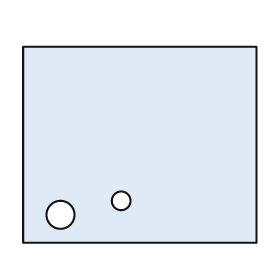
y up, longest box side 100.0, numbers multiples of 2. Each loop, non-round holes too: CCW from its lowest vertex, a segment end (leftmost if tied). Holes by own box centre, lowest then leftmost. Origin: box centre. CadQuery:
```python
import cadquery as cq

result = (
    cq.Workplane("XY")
    .moveTo(-50.0, -42.0)
    .lineTo(50.0, -42.0)
    .lineTo(50.0, 42.0)
    .lineTo(-50.0, 42.0)
    .close()
    .moveTo(-34.0, -30.0)
    .circle(6.0)
    .moveTo(-8.0, -24.0)
    .circle(4.0)
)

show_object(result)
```